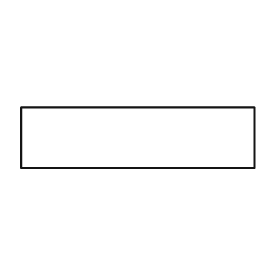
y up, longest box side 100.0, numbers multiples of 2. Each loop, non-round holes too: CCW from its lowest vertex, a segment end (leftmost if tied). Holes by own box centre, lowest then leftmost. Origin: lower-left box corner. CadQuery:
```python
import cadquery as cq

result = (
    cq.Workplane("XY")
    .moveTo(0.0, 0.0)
    .lineTo(100.0, 0.0)
    .lineTo(100.0, 26.0)
    .lineTo(0.0, 26.0)
    .close()
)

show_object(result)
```